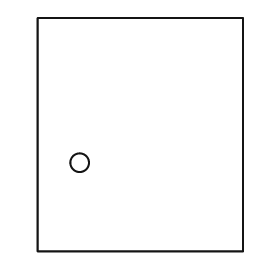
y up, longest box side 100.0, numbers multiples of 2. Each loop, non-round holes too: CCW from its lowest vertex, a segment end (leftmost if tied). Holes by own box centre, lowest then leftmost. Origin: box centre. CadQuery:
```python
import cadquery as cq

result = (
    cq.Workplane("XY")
    .moveTo(-44.0, -50.0)
    .lineTo(44.0, -50.0)
    .lineTo(44.0, 50.0)
    .lineTo(-44.0, 50.0)
    .close()
    .moveTo(-26.0, -12.0)
    .circle(4.0)
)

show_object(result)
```